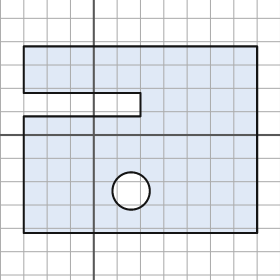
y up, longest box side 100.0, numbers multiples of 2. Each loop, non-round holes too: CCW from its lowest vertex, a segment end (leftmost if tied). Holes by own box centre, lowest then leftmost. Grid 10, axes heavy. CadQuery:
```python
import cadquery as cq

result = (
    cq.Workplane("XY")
    .moveTo(-30.0, -42.0)
    .lineTo(70.0, -42.0)
    .lineTo(70.0, 38.0)
    .lineTo(-30.0, 38.0)
    .lineTo(-30.0, 18.0)
    .lineTo(20.0, 18.0)
    .lineTo(20.0, 8.0)
    .lineTo(-30.0, 8.0)
    .close()
    .moveTo(16.0, -24.0)
    .circle(8.0)
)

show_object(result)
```